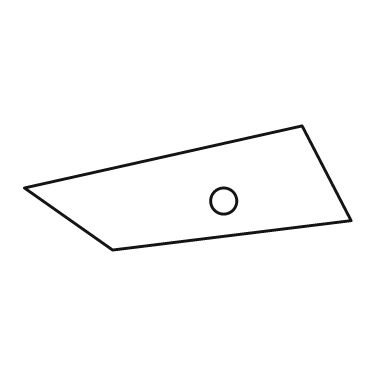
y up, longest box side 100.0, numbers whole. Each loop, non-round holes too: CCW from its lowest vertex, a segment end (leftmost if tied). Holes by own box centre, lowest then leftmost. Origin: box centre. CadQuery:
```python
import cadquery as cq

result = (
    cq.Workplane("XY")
    .moveTo(-23.0, -19.0)
    .lineTo(50.0, -10.0)
    .lineTo(35.0, 19.0)
    .lineTo(-50.0, 0.0)
    .close()
    .moveTo(11.0, -4.0)
    .circle(4.0)
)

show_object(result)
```